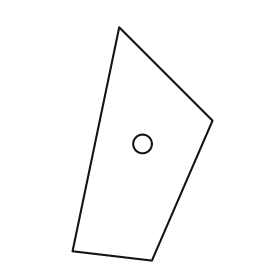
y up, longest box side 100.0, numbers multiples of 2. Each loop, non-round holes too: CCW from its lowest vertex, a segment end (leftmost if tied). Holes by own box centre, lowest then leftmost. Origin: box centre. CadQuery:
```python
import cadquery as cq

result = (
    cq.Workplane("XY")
    .moveTo(4.0, -50.0)
    .lineTo(30.0, 10.0)
    .lineTo(-10.0, 50.0)
    .lineTo(-30.0, -46.0)
    .close()
    .moveTo(0.0, 0.0)
    .circle(4.0)
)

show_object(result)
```